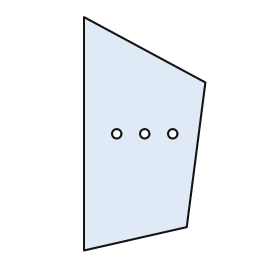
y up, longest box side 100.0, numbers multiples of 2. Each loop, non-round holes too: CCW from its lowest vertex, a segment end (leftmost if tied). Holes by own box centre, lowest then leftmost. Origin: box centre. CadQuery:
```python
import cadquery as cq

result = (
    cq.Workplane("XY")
    .moveTo(-26.0, -50.0)
    .lineTo(18.0, -40.0)
    .lineTo(26.0, 22.0)
    .lineTo(-26.0, 50.0)
    .close()
    .moveTo(-12.0, 0.0)
    .circle(2.0)
    .moveTo(0.0, 0.0)
    .circle(2.0)
    .moveTo(12.0, 0.0)
    .circle(2.0)
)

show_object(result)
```